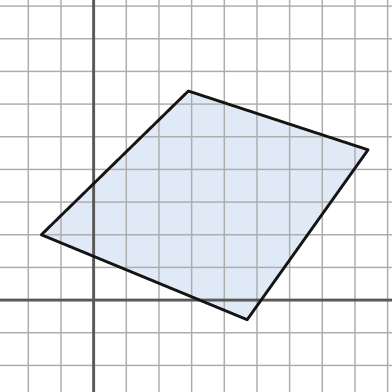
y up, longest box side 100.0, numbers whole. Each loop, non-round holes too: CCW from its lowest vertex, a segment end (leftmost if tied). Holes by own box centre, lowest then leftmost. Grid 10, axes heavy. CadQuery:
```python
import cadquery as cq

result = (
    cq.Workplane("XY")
    .moveTo(47.0, -6.0)
    .lineTo(84.0, 46.0)
    .lineTo(29.0, 64.0)
    .lineTo(-16.0, 20.0)
    .close()
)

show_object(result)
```